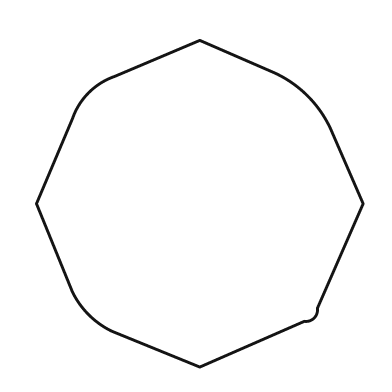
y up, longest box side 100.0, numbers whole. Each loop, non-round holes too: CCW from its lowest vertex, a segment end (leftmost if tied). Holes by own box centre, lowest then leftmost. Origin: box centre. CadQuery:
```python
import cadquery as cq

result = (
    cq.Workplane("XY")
    .moveTo(0.0, -50.0)
    .lineTo(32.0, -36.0)
    .threePointArc((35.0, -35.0), (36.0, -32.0))
    .lineTo(50.0, 0.0)
    .lineTo(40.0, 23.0)
    .threePointArc((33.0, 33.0), (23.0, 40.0))
    .lineTo(0.0, 50.0)
    .lineTo(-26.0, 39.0)
    .threePointArc((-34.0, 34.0), (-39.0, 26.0))
    .lineTo(-50.0, 0.0)
    .lineTo(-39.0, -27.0)
    .threePointArc((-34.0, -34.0), (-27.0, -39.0))
    .close()
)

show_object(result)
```